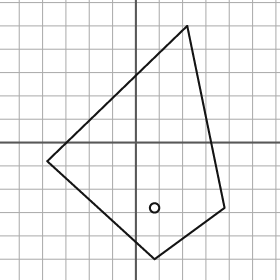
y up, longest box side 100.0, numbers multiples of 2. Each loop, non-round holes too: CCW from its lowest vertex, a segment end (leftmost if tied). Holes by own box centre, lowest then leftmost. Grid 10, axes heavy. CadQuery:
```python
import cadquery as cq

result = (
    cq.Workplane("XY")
    .moveTo(8.0, -50.0)
    .lineTo(38.0, -28.0)
    .lineTo(22.0, 50.0)
    .lineTo(-38.0, -8.0)
    .close()
    .moveTo(8.0, -28.0)
    .circle(2.0)
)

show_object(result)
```